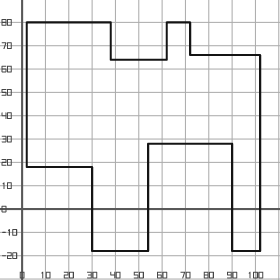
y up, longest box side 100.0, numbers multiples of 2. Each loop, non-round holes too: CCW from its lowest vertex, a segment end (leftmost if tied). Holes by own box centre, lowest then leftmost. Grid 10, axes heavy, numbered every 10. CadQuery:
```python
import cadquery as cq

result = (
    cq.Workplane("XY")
    .moveTo(30.0, -18.0)
    .lineTo(54.0, -18.0)
    .lineTo(54.0, 28.0)
    .lineTo(90.0, 28.0)
    .lineTo(90.0, -18.0)
    .lineTo(102.0, -18.0)
    .lineTo(102.0, 66.0)
    .lineTo(72.0, 66.0)
    .lineTo(72.0, 80.0)
    .lineTo(62.0, 80.0)
    .lineTo(62.0, 64.0)
    .lineTo(38.0, 64.0)
    .lineTo(38.0, 80.0)
    .lineTo(2.0, 80.0)
    .lineTo(2.0, 18.0)
    .lineTo(30.0, 18.0)
    .close()
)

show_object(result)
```